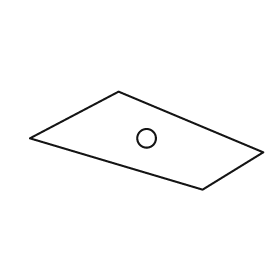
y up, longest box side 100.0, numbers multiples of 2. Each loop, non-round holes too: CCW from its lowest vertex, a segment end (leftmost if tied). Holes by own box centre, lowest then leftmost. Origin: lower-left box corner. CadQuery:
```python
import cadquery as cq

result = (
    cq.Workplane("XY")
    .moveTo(74.0, 0.0)
    .lineTo(100.0, 16.0)
    .lineTo(38.0, 42.0)
    .lineTo(0.0, 22.0)
    .close()
    .moveTo(50.0, 22.0)
    .circle(4.0)
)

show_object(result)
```